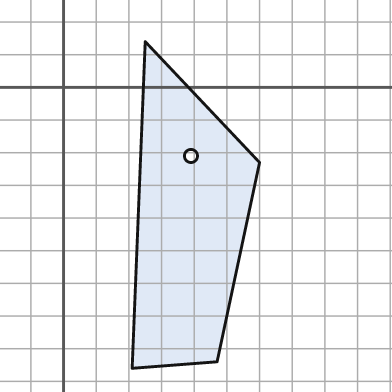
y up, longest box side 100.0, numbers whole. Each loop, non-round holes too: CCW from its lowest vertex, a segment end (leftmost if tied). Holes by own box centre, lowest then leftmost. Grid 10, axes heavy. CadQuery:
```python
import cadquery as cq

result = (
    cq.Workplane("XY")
    .moveTo(21.0, -86.0)
    .lineTo(47.0, -84.0)
    .lineTo(60.0, -23.0)
    .lineTo(25.0, 14.0)
    .close()
    .moveTo(39.0, -21.0)
    .circle(2.0)
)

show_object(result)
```